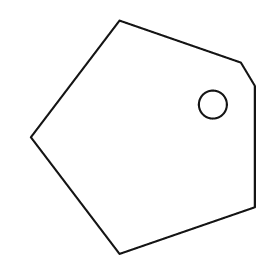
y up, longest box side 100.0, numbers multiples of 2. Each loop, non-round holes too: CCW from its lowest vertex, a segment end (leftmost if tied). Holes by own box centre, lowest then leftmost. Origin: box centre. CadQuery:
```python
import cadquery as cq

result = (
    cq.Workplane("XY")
    .moveTo(-10.0, -50.0)
    .lineTo(48.0, -30.0)
    .lineTo(48.0, 22.0)
    .lineTo(42.0, 32.0)
    .lineTo(-10.0, 50.0)
    .lineTo(-48.0, 0.0)
    .close()
    .moveTo(30.0, 14.0)
    .circle(6.0)
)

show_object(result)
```